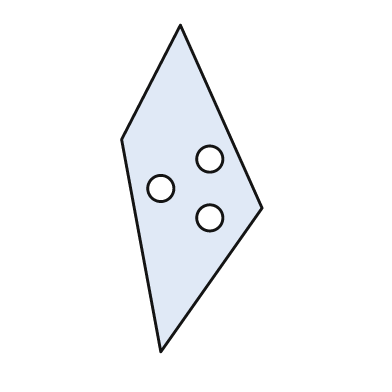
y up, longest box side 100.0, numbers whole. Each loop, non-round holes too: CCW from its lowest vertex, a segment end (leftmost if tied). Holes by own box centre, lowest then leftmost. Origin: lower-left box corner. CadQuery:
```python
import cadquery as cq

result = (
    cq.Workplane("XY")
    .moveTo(12.0, 0.0)
    .lineTo(43.0, 44.0)
    .lineTo(18.0, 100.0)
    .lineTo(0.0, 65.0)
    .close()
    .moveTo(27.0, 41.0)
    .circle(4.0)
    .moveTo(12.0, 50.0)
    .circle(4.0)
    .moveTo(27.0, 59.0)
    .circle(4.0)
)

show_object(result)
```